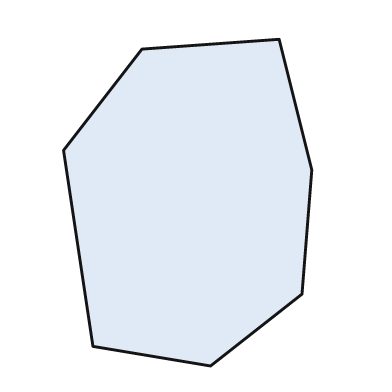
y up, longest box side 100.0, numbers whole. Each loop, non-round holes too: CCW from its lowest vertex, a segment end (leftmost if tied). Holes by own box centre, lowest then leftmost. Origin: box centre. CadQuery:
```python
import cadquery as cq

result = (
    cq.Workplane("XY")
    .moveTo(7.0, -50.0)
    .lineTo(35.0, -28.0)
    .lineTo(38.0, 10.0)
    .lineTo(28.0, 50.0)
    .lineTo(-14.0, 47.0)
    .lineTo(-38.0, 16.0)
    .lineTo(-29.0, -44.0)
    .close()
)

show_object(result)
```